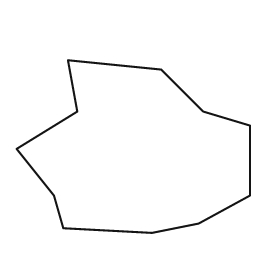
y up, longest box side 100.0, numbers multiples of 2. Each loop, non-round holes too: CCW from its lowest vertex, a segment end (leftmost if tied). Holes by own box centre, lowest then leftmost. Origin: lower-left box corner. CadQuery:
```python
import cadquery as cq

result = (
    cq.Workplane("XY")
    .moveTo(58.0, 0.0)
    .lineTo(78.0, 4.0)
    .lineTo(100.0, 16.0)
    .lineTo(100.0, 46.0)
    .lineTo(80.0, 52.0)
    .lineTo(62.0, 70.0)
    .lineTo(22.0, 74.0)
    .lineTo(26.0, 52.0)
    .lineTo(0.0, 36.0)
    .lineTo(16.0, 16.0)
    .lineTo(20.0, 2.0)
    .close()
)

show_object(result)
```